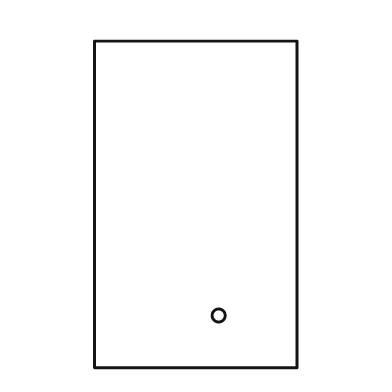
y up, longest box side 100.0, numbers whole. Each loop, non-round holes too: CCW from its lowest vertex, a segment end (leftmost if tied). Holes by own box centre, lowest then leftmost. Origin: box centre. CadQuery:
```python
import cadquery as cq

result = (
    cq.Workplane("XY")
    .moveTo(-31.0, -50.0)
    .lineTo(31.0, -50.0)
    .lineTo(31.0, 50.0)
    .lineTo(-31.0, 50.0)
    .close()
    .moveTo(7.0, -34.0)
    .circle(2.0)
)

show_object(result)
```